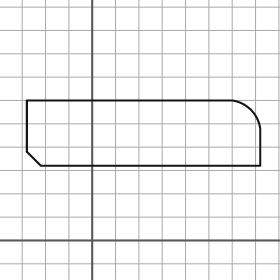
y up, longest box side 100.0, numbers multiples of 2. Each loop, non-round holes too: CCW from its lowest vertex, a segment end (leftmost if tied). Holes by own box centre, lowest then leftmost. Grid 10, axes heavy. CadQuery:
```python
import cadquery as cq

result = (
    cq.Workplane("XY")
    .moveTo(-22.0, 32.0)
    .lineTo(72.0, 32.0)
    .lineTo(72.0, 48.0)
    .threePointArc((68.0, 56.0), (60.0, 60.0))
    .lineTo(-28.0, 60.0)
    .lineTo(-28.0, 38.0)
    .close()
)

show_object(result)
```